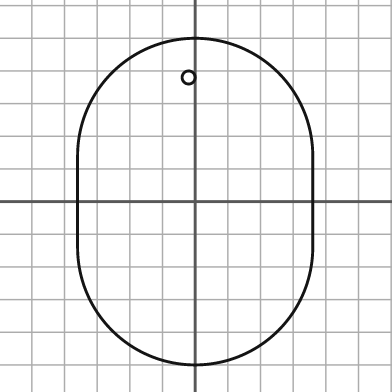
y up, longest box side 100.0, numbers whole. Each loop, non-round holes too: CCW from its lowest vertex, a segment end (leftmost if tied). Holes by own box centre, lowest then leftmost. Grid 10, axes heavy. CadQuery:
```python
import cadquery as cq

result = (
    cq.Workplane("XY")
    .moveTo(-36.0, -14.0)
    .threePointArc((0.0, -50.0), (36.0, -14.0))
    .lineTo(36.0, 14.0)
    .threePointArc((0.0, 50.0), (-36.0, 14.0))
    .close()
    .moveTo(-2.0, 38.0)
    .circle(2.0)
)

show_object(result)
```